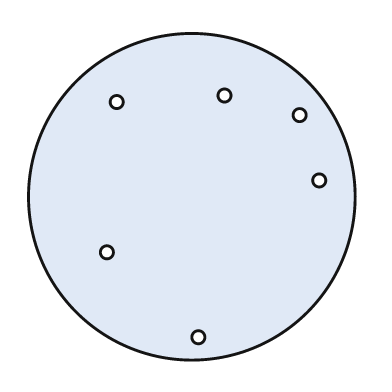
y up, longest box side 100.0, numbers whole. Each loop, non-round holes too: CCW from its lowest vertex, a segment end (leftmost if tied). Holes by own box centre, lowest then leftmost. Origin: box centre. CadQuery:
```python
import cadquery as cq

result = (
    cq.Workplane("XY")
    .moveTo(0.0, 0.0)
    .circle(50.0)
    .moveTo(2.0, -43.0)
    .circle(2.0)
    .moveTo(-26.0, -17.0)
    .circle(2.0)
    .moveTo(39.0, 5.0)
    .circle(2.0)
    .moveTo(33.0, 25.0)
    .circle(2.0)
    .moveTo(-23.0, 29.0)
    .circle(2.0)
    .moveTo(10.0, 31.0)
    .circle(2.0)
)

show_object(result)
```